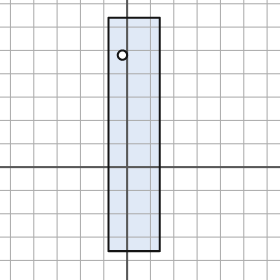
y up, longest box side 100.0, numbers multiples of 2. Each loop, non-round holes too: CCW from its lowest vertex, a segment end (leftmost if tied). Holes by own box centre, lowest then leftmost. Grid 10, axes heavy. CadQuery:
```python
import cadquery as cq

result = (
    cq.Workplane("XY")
    .moveTo(-8.0, -36.0)
    .lineTo(14.0, -36.0)
    .lineTo(14.0, 64.0)
    .lineTo(-8.0, 64.0)
    .close()
    .moveTo(-2.0, 48.0)
    .circle(2.0)
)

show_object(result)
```